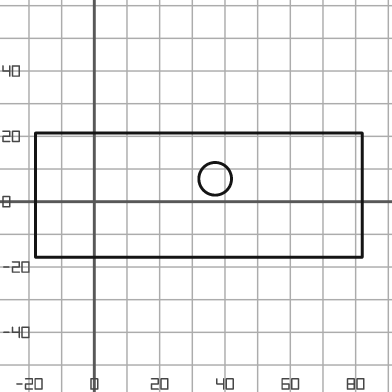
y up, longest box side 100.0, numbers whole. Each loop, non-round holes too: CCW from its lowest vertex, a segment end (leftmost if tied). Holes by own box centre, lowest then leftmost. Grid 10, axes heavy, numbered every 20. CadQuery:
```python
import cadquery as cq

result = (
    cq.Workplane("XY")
    .moveTo(-18.0, -17.0)
    .lineTo(82.0, -17.0)
    .lineTo(82.0, 21.0)
    .lineTo(-18.0, 21.0)
    .close()
    .moveTo(37.0, 7.0)
    .circle(5.0)
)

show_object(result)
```